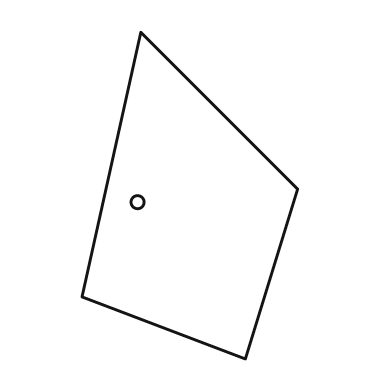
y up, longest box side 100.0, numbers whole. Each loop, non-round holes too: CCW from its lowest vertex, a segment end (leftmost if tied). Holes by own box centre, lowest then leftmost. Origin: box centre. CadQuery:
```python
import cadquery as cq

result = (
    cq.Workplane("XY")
    .moveTo(17.0, -50.0)
    .lineTo(33.0, 2.0)
    .lineTo(-15.0, 50.0)
    .lineTo(-33.0, -31.0)
    .close()
    .moveTo(-16.0, -2.0)
    .circle(2.0)
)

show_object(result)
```